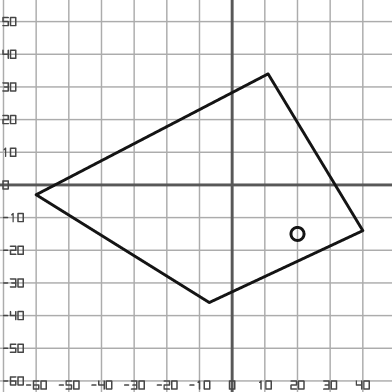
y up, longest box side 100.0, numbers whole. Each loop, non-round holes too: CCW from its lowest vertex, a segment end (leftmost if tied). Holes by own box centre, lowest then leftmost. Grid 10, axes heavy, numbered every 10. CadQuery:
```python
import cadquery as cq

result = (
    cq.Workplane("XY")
    .moveTo(-7.0, -36.0)
    .lineTo(40.0, -14.0)
    .lineTo(11.0, 34.0)
    .lineTo(-60.0, -3.0)
    .close()
    .moveTo(20.0, -15.0)
    .circle(2.0)
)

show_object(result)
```